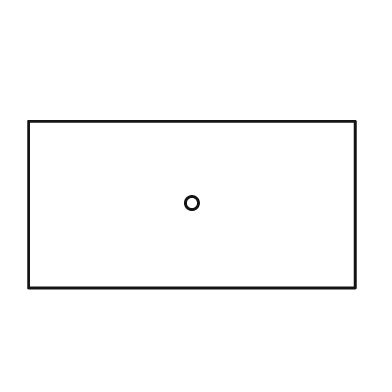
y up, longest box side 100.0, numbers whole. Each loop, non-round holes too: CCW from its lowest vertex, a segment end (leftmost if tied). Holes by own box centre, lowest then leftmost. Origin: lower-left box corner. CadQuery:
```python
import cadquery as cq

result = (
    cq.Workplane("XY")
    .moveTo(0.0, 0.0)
    .lineTo(100.0, 0.0)
    .lineTo(100.0, 51.0)
    .lineTo(0.0, 51.0)
    .close()
    .moveTo(50.0, 26.0)
    .circle(2.0)
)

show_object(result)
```